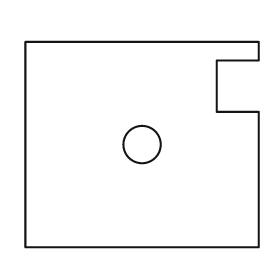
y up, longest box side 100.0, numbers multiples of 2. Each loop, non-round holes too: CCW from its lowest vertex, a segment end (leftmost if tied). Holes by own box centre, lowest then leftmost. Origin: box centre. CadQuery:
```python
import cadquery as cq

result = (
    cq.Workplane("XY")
    .moveTo(-50.0, -44.0)
    .lineTo(50.0, -44.0)
    .lineTo(50.0, 14.0)
    .lineTo(32.0, 14.0)
    .lineTo(32.0, 36.0)
    .lineTo(50.0, 36.0)
    .lineTo(50.0, 44.0)
    .lineTo(-50.0, 44.0)
    .close()
    .moveTo(0.0, 0.0)
    .circle(8.0)
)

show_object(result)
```